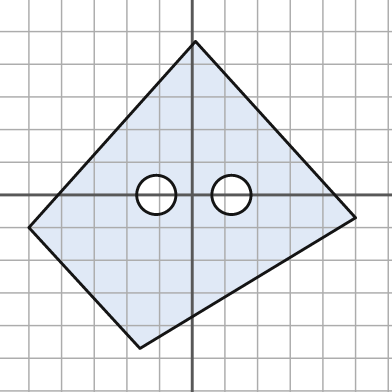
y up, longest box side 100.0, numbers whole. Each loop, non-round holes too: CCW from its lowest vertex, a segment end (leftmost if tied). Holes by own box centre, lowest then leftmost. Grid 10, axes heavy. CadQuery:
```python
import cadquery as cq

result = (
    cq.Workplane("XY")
    .moveTo(-16.0, -47.0)
    .lineTo(50.0, -7.0)
    .lineTo(1.0, 47.0)
    .lineTo(-50.0, -10.0)
    .close()
    .moveTo(-11.0, 0.0)
    .circle(6.0)
    .moveTo(12.0, 0.0)
    .circle(6.0)
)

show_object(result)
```